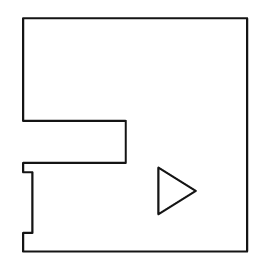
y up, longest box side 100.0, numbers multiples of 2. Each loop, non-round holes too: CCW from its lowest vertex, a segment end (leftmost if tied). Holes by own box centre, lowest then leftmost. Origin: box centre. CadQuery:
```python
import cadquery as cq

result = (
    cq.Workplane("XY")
    .moveTo(-48.0, -50.0)
    .lineTo(48.0, -50.0)
    .lineTo(48.0, 50.0)
    .lineTo(-48.0, 50.0)
    .lineTo(-48.0, 6.0)
    .lineTo(-4.0, 6.0)
    .lineTo(-4.0, -12.0)
    .lineTo(-48.0, -12.0)
    .lineTo(-48.0, -16.0)
    .lineTo(-44.0, -16.0)
    .lineTo(-44.0, -42.0)
    .lineTo(-48.0, -42.0)
    .close()
    .moveTo(10.0, -34.0)
    .lineTo(26.0, -24.0)
    .lineTo(10.0, -14.0)
    .close()
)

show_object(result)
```